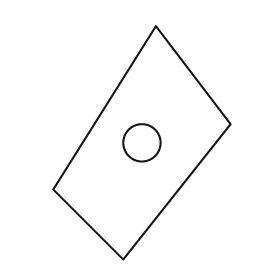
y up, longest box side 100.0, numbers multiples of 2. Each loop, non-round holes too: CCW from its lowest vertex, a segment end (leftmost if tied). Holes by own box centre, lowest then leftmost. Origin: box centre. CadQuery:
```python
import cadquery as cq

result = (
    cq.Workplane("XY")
    .moveTo(-8.0, -50.0)
    .lineTo(38.0, 8.0)
    .lineTo(6.0, 50.0)
    .lineTo(-38.0, -20.0)
    .close()
    .moveTo(0.0, 0.0)
    .circle(8.0)
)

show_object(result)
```